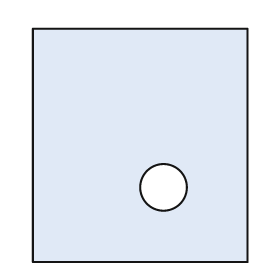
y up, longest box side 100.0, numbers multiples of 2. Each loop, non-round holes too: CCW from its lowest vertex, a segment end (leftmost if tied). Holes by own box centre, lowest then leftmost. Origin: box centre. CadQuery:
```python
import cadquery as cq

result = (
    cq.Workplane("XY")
    .moveTo(-46.0, -50.0)
    .lineTo(46.0, -50.0)
    .lineTo(46.0, 50.0)
    .lineTo(-46.0, 50.0)
    .close()
    .moveTo(10.0, -18.0)
    .circle(10.0)
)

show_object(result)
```